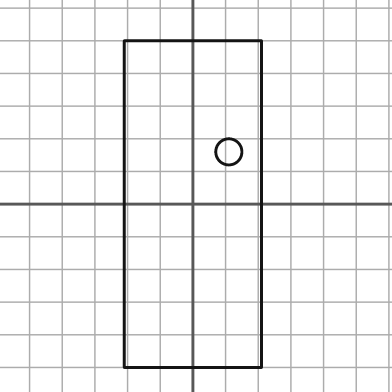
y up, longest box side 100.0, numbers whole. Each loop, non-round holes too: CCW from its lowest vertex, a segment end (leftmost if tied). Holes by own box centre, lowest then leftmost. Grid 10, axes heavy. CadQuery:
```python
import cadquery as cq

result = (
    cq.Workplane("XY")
    .moveTo(-21.0, -50.0)
    .lineTo(21.0, -50.0)
    .lineTo(21.0, 50.0)
    .lineTo(-21.0, 50.0)
    .close()
    .moveTo(11.0, 16.0)
    .circle(4.0)
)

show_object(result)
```